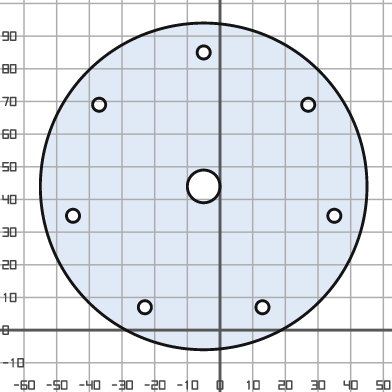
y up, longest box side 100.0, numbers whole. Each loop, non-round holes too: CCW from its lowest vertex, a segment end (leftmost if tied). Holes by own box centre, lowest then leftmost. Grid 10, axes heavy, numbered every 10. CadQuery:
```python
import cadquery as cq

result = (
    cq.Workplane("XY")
    .moveTo(-5.0, 44.0)
    .circle(50.0)
    .moveTo(-23.0, 7.0)
    .circle(2.0)
    .moveTo(13.0, 7.0)
    .circle(2.0)
    .moveTo(-45.0, 35.0)
    .circle(2.0)
    .moveTo(35.0, 35.0)
    .circle(2.0)
    .moveTo(-5.0, 44.0)
    .circle(5.0)
    .moveTo(-37.0, 69.0)
    .circle(2.0)
    .moveTo(27.0, 69.0)
    .circle(2.0)
    .moveTo(-5.0, 85.0)
    .circle(2.0)
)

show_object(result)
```